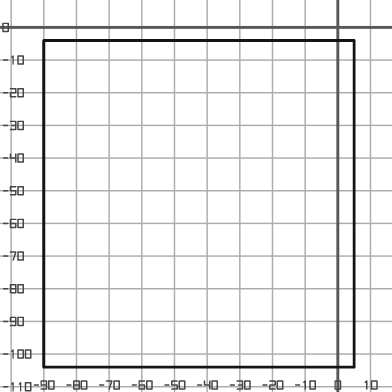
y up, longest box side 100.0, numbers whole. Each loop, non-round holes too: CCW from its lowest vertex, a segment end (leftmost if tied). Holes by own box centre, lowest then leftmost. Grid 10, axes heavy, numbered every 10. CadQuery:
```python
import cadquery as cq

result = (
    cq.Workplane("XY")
    .moveTo(-90.0, -104.0)
    .lineTo(5.0, -104.0)
    .lineTo(5.0, -4.0)
    .lineTo(-90.0, -4.0)
    .close()
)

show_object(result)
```